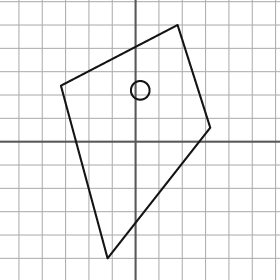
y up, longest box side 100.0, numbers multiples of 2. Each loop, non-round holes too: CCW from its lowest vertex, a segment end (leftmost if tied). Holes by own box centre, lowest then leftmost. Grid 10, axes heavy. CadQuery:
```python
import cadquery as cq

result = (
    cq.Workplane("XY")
    .moveTo(-12.0, -50.0)
    .lineTo(32.0, 6.0)
    .lineTo(18.0, 50.0)
    .lineTo(-32.0, 24.0)
    .close()
    .moveTo(2.0, 22.0)
    .circle(4.0)
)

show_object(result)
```